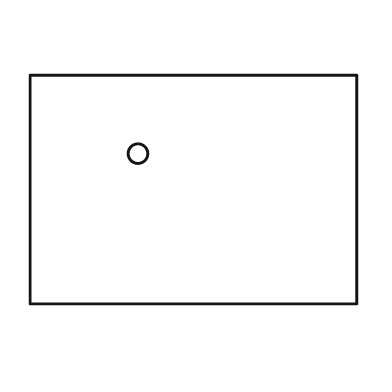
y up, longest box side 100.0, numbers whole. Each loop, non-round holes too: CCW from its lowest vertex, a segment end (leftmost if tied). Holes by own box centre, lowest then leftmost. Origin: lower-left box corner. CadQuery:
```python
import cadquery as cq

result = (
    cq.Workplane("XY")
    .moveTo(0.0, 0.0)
    .lineTo(100.0, 0.0)
    .lineTo(100.0, 70.0)
    .lineTo(0.0, 70.0)
    .close()
    .moveTo(33.0, 46.0)
    .circle(3.0)
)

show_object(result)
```